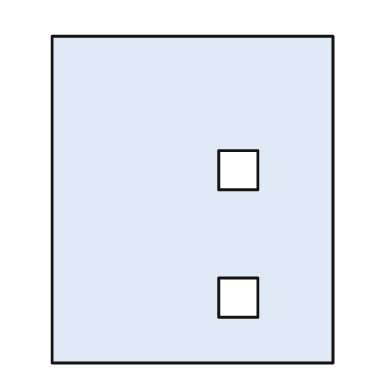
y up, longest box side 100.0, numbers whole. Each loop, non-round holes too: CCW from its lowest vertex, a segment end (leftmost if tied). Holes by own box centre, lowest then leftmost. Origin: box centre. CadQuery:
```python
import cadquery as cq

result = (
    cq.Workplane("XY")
    .moveTo(-43.0, -50.0)
    .lineTo(43.0, -50.0)
    .lineTo(43.0, 50.0)
    .lineTo(-43.0, 50.0)
    .close()
    .moveTo(8.0, -36.0)
    .lineTo(20.0, -36.0)
    .lineTo(20.0, -24.0)
    .lineTo(8.0, -24.0)
    .close()
    .moveTo(8.0, 3.0)
    .lineTo(20.0, 3.0)
    .lineTo(20.0, 15.0)
    .lineTo(8.0, 15.0)
    .close()
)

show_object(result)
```